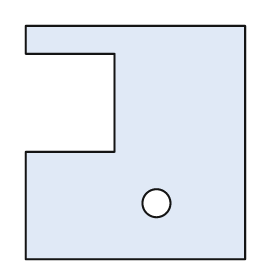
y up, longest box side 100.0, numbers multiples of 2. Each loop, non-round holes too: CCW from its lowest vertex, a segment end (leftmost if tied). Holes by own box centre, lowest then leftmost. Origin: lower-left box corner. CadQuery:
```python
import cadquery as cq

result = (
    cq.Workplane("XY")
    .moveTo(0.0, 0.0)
    .lineTo(94.0, 0.0)
    .lineTo(94.0, 100.0)
    .lineTo(0.0, 100.0)
    .lineTo(0.0, 88.0)
    .lineTo(38.0, 88.0)
    .lineTo(38.0, 46.0)
    .lineTo(0.0, 46.0)
    .close()
    .moveTo(56.0, 24.0)
    .circle(6.0)
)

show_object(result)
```